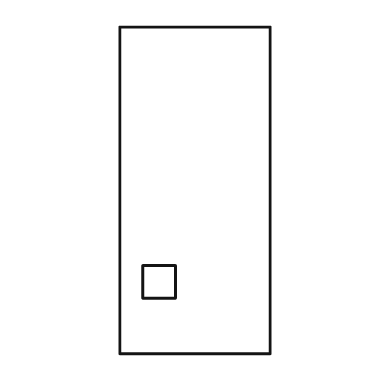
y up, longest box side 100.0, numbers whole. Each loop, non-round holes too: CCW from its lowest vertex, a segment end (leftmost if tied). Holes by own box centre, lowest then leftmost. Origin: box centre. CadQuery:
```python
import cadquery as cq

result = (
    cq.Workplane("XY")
    .moveTo(-23.0, -50.0)
    .lineTo(23.0, -50.0)
    .lineTo(23.0, 50.0)
    .lineTo(-23.0, 50.0)
    .close()
    .moveTo(-16.0, -33.0)
    .lineTo(-6.0, -33.0)
    .lineTo(-6.0, -23.0)
    .lineTo(-16.0, -23.0)
    .close()
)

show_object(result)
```